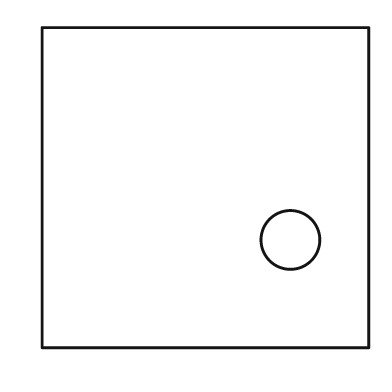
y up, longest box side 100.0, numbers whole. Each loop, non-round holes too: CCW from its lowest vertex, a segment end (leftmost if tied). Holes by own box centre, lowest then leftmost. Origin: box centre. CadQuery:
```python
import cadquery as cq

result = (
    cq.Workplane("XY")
    .moveTo(-50.0, -49.0)
    .lineTo(50.0, -49.0)
    .lineTo(50.0, 49.0)
    .lineTo(-50.0, 49.0)
    .close()
    .moveTo(26.0, -16.0)
    .circle(9.0)
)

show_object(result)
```